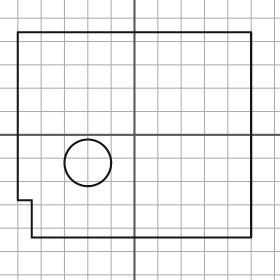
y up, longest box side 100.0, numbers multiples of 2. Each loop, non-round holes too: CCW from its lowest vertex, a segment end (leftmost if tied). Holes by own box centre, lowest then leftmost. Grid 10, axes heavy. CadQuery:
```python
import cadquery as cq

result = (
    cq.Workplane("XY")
    .moveTo(-44.0, -44.0)
    .lineTo(50.0, -44.0)
    .lineTo(50.0, 44.0)
    .lineTo(-50.0, 44.0)
    .lineTo(-50.0, -28.0)
    .lineTo(-44.0, -28.0)
    .close()
    .moveTo(-20.0, -12.0)
    .circle(10.0)
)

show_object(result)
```